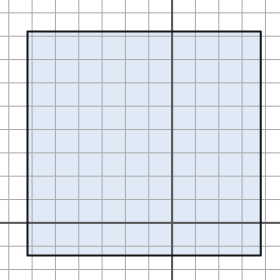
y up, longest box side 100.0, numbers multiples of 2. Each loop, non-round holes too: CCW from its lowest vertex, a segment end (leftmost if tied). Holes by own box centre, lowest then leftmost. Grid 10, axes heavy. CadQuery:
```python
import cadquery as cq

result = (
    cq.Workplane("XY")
    .moveTo(-62.0, -14.0)
    .lineTo(38.0, -14.0)
    .lineTo(38.0, 82.0)
    .lineTo(-62.0, 82.0)
    .close()
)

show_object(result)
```